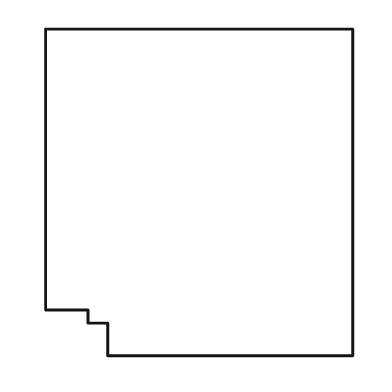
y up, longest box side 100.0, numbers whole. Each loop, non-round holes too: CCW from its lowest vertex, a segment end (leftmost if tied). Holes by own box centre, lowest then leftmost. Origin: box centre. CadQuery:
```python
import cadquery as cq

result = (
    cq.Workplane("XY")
    .moveTo(-28.0, -50.0)
    .lineTo(47.0, -50.0)
    .lineTo(47.0, 50.0)
    .lineTo(-47.0, 50.0)
    .lineTo(-47.0, -36.0)
    .lineTo(-34.0, -36.0)
    .lineTo(-34.0, -40.0)
    .lineTo(-28.0, -40.0)
    .close()
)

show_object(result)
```